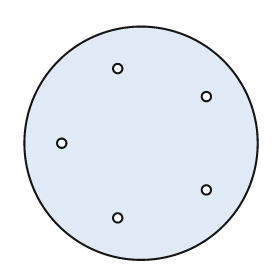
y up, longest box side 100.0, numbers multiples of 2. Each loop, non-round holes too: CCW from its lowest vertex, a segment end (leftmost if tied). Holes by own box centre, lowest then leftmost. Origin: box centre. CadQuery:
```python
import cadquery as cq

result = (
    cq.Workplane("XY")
    .moveTo(0.0, 0.0)
    .circle(50.0)
    .moveTo(-10.0, -32.0)
    .circle(2.0)
    .moveTo(28.0, -20.0)
    .circle(2.0)
    .moveTo(-34.0, 0.0)
    .circle(2.0)
    .moveTo(28.0, 20.0)
    .circle(2.0)
    .moveTo(-10.0, 32.0)
    .circle(2.0)
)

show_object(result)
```